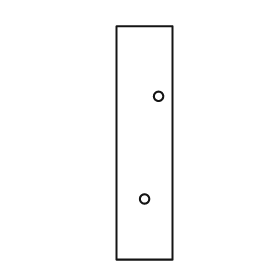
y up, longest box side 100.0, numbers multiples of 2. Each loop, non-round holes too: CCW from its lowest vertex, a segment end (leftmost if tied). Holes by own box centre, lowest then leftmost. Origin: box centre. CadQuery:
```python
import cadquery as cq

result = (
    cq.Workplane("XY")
    .moveTo(-12.0, -50.0)
    .lineTo(12.0, -50.0)
    .lineTo(12.0, 50.0)
    .lineTo(-12.0, 50.0)
    .close()
    .moveTo(0.0, -24.0)
    .circle(2.0)
    .moveTo(6.0, 20.0)
    .circle(2.0)
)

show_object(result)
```